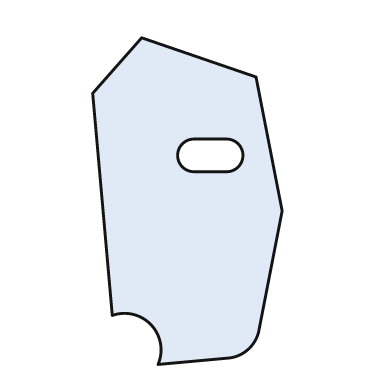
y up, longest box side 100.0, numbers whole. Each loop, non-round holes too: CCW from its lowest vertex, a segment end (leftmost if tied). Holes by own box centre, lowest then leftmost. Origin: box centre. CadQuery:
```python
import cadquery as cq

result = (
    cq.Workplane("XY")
    .moveTo(-9.0, -50.0)
    .lineTo(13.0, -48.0)
    .threePointArc((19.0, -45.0), (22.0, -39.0))
    .lineTo(29.0, -3.0)
    .lineTo(21.0, 38.0)
    .lineTo(-14.0, 50.0)
    .lineTo(-29.0, 33.0)
    .lineTo(-23.0, -35.0)
    .threePointArc((-11.0, -38.0), (-9.0, -50.0))
    .close()
    .moveTo(2.0, 9.0)
    .lineTo(12.0, 9.0)
    .threePointArc((17.0, 14.0), (12.0, 19.0))
    .lineTo(2.0, 19.0)
    .threePointArc((-3.0, 14.0), (2.0, 9.0))
    .close()
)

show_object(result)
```